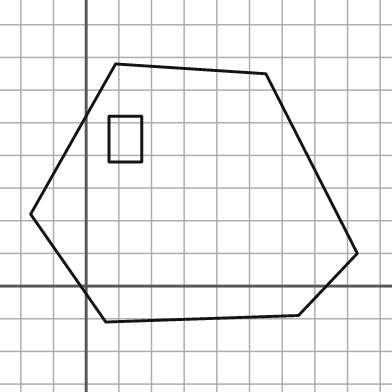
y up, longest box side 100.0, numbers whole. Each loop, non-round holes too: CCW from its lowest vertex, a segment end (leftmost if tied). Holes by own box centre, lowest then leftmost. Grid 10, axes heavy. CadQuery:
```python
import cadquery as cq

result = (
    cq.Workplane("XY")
    .moveTo(6.0, -11.0)
    .lineTo(65.0, -9.0)
    .lineTo(83.0, 10.0)
    .lineTo(55.0, 65.0)
    .lineTo(9.0, 68.0)
    .lineTo(-17.0, 22.0)
    .close()
    .moveTo(7.0, 38.0)
    .lineTo(17.0, 38.0)
    .lineTo(17.0, 52.0)
    .lineTo(7.0, 52.0)
    .close()
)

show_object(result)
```